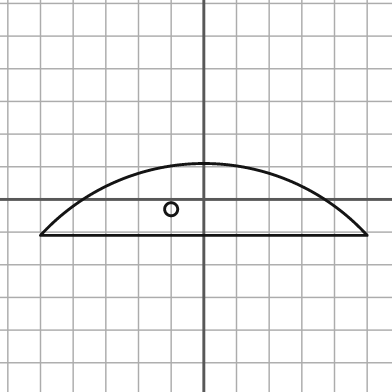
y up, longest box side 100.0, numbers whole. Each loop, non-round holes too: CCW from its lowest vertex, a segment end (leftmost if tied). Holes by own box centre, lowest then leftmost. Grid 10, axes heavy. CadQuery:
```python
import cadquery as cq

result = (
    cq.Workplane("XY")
    .moveTo(-50.0, -11.0)
    .lineTo(50.0, -11.0)
    .threePointArc((0.0, 11.0), (-50.0, -11.0))
    .close()
    .moveTo(-10.0, -3.0)
    .circle(2.0)
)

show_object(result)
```